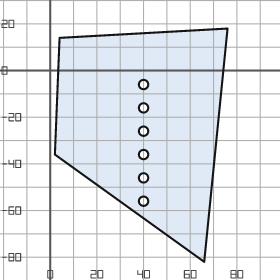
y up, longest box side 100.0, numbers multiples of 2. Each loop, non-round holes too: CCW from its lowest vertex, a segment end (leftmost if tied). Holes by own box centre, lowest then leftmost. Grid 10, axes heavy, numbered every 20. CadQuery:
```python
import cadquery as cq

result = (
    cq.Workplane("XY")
    .moveTo(66.0, -82.0)
    .lineTo(76.0, 18.0)
    .lineTo(4.0, 14.0)
    .lineTo(2.0, -36.0)
    .close()
    .moveTo(40.0, -56.0)
    .circle(2.0)
    .moveTo(40.0, -46.0)
    .circle(2.0)
    .moveTo(40.0, -36.0)
    .circle(2.0)
    .moveTo(40.0, -26.0)
    .circle(2.0)
    .moveTo(40.0, -16.0)
    .circle(2.0)
    .moveTo(40.0, -6.0)
    .circle(2.0)
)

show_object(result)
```